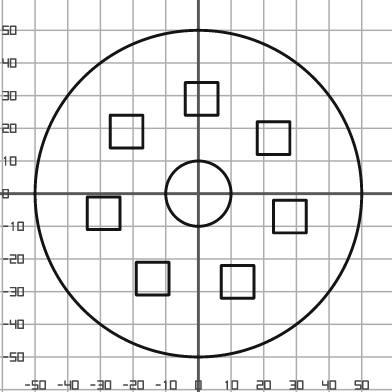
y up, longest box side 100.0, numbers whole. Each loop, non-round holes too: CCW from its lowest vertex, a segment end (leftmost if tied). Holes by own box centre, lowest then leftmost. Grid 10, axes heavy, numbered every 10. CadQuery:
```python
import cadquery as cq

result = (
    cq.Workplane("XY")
    .moveTo(0.0, 0.0)
    .circle(50.0)
    .moveTo(7.0, -32.0)
    .lineTo(17.0, -32.0)
    .lineTo(17.0, -22.0)
    .lineTo(7.0, -22.0)
    .close()
    .moveTo(-19.0, -31.0)
    .lineTo(-9.0, -31.0)
    .lineTo(-9.0, -21.0)
    .lineTo(-19.0, -21.0)
    .close()
    .moveTo(23.0, -12.0)
    .lineTo(33.0, -12.0)
    .lineTo(33.0, -2.0)
    .lineTo(23.0, -2.0)
    .close()
    .moveTo(-34.0, -11.0)
    .lineTo(-24.0, -11.0)
    .lineTo(-24.0, -1.0)
    .lineTo(-34.0, -1.0)
    .close()
    .moveTo(0.0, 0.0)
    .circle(10.0)
    .moveTo(18.0, 12.0)
    .lineTo(28.0, 12.0)
    .lineTo(28.0, 22.0)
    .lineTo(18.0, 22.0)
    .close()
    .moveTo(-27.0, 14.0)
    .lineTo(-17.0, 14.0)
    .lineTo(-17.0, 24.0)
    .lineTo(-27.0, 24.0)
    .close()
    .moveTo(-4.0, 24.0)
    .lineTo(6.0, 24.0)
    .lineTo(6.0, 34.0)
    .lineTo(-4.0, 34.0)
    .close()
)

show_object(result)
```